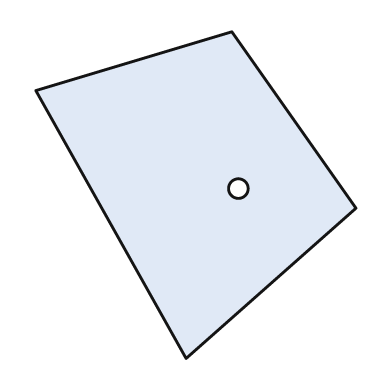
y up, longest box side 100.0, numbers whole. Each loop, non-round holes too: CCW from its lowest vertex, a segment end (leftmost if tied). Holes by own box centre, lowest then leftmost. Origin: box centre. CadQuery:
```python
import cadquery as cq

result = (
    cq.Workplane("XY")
    .moveTo(-3.0, -50.0)
    .lineTo(49.0, -4.0)
    .lineTo(11.0, 50.0)
    .lineTo(-49.0, 32.0)
    .close()
    .moveTo(13.0, 2.0)
    .circle(3.0)
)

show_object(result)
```